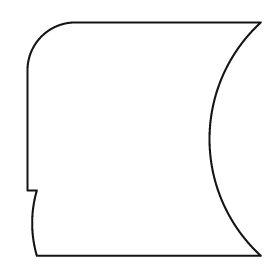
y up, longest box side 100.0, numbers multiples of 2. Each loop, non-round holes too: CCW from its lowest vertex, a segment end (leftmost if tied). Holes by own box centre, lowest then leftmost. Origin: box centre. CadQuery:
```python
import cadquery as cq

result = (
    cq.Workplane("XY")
    .moveTo(-46.0, -50.0)
    .lineTo(50.0, -50.0)
    .threePointArc((28.0, 0.0), (50.0, 50.0))
    .lineTo(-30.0, 50.0)
    .threePointArc((-44.0, 44.0), (-50.0, 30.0))
    .lineTo(-50.0, -22.0)
    .lineTo(-46.0, -22.0)
    .threePointArc((-48.0, -36.0), (-46.0, -50.0))
    .close()
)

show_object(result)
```